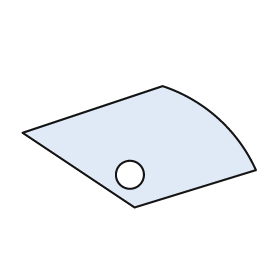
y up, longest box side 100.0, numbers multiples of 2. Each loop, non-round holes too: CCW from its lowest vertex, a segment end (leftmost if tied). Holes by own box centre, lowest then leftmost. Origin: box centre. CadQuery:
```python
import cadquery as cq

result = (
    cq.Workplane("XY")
    .moveTo(-2.0, -26.0)
    .lineTo(50.0, -10.0)
    .threePointArc((34.0, 12.0), (10.0, 26.0))
    .lineTo(-50.0, 6.0)
    .close()
    .moveTo(-4.0, -12.0)
    .circle(6.0)
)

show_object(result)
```